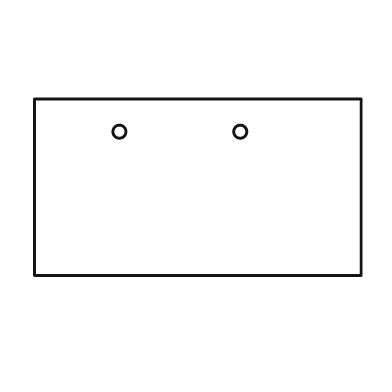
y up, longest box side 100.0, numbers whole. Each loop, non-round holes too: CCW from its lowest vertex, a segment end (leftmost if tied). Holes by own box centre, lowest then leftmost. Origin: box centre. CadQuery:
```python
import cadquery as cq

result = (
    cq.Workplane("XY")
    .moveTo(-50.0, -27.0)
    .lineTo(50.0, -27.0)
    .lineTo(50.0, 27.0)
    .lineTo(-50.0, 27.0)
    .close()
    .moveTo(-24.0, 17.0)
    .circle(2.0)
    .moveTo(13.0, 17.0)
    .circle(2.0)
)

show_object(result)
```